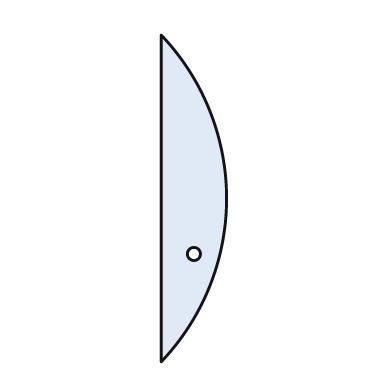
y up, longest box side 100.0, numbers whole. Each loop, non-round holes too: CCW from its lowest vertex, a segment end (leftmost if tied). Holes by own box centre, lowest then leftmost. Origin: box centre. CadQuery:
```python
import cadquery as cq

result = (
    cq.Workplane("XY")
    .moveTo(-10.0, -50.0)
    .threePointArc((10.0, 0.0), (-10.0, 50.0))
    .close()
    .moveTo(0.0, -17.0)
    .circle(2.0)
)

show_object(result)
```